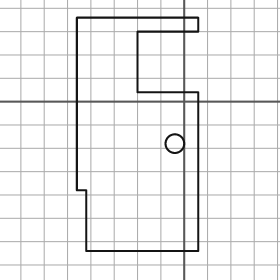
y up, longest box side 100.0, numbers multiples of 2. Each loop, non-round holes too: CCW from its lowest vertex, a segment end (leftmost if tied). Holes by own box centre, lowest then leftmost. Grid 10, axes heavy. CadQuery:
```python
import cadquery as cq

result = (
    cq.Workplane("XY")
    .moveTo(-42.0, -64.0)
    .lineTo(6.0, -64.0)
    .lineTo(6.0, 4.0)
    .lineTo(-20.0, 4.0)
    .lineTo(-20.0, 30.0)
    .lineTo(6.0, 30.0)
    .lineTo(6.0, 36.0)
    .lineTo(-46.0, 36.0)
    .lineTo(-46.0, -38.0)
    .lineTo(-42.0, -38.0)
    .close()
    .moveTo(-4.0, -18.0)
    .circle(4.0)
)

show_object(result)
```